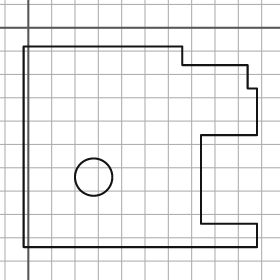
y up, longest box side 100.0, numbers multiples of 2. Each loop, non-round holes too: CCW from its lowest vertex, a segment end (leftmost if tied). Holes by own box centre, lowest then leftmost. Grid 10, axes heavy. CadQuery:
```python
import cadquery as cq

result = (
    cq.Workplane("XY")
    .moveTo(-2.0, -94.0)
    .lineTo(98.0, -94.0)
    .lineTo(98.0, -84.0)
    .lineTo(74.0, -84.0)
    .lineTo(74.0, -46.0)
    .lineTo(98.0, -46.0)
    .lineTo(98.0, -26.0)
    .lineTo(94.0, -26.0)
    .lineTo(94.0, -16.0)
    .lineTo(66.0, -16.0)
    .lineTo(66.0, -8.0)
    .lineTo(-2.0, -8.0)
    .close()
    .moveTo(28.0, -64.0)
    .circle(8.0)
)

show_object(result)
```